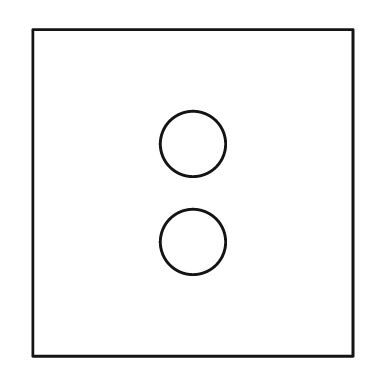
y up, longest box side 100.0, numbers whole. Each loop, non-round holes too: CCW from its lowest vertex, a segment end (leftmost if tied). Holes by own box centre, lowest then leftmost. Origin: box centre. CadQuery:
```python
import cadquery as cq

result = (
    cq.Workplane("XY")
    .moveTo(-49.0, -50.0)
    .lineTo(49.0, -50.0)
    .lineTo(49.0, 50.0)
    .lineTo(-49.0, 50.0)
    .close()
    .moveTo(0.0, -15.0)
    .circle(10.0)
    .moveTo(0.0, 15.0)
    .circle(10.0)
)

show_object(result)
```